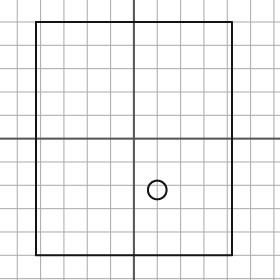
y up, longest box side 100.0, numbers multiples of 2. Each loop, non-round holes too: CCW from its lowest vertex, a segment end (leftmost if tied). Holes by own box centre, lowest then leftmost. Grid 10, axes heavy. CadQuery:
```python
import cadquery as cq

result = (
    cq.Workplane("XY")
    .moveTo(-42.0, -50.0)
    .lineTo(42.0, -50.0)
    .lineTo(42.0, 50.0)
    .lineTo(-42.0, 50.0)
    .close()
    .moveTo(10.0, -22.0)
    .circle(4.0)
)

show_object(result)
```